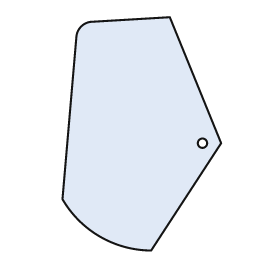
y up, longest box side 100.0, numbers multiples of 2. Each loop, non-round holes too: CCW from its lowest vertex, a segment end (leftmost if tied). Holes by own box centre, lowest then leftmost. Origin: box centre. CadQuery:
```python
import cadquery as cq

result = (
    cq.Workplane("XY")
    .moveTo(4.0, -50.0)
    .lineTo(34.0, -4.0)
    .lineTo(12.0, 50.0)
    .lineTo(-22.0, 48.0)
    .threePointArc((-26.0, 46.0), (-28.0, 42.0))
    .lineTo(-34.0, -28.0)
    .threePointArc((-18.0, -44.0), (4.0, -50.0))
    .close()
    .moveTo(26.0, -4.0)
    .circle(2.0)
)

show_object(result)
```